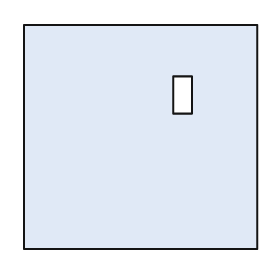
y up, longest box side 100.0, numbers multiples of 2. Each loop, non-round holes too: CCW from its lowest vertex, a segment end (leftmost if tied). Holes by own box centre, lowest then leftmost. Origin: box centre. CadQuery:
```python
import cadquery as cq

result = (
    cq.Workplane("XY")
    .moveTo(-50.0, -48.0)
    .lineTo(50.0, -48.0)
    .lineTo(50.0, 48.0)
    .lineTo(-50.0, 48.0)
    .close()
    .moveTo(14.0, 10.0)
    .lineTo(22.0, 10.0)
    .lineTo(22.0, 26.0)
    .lineTo(14.0, 26.0)
    .close()
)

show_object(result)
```